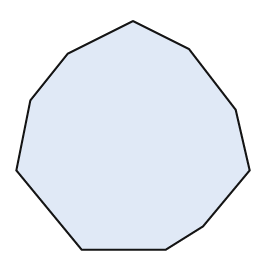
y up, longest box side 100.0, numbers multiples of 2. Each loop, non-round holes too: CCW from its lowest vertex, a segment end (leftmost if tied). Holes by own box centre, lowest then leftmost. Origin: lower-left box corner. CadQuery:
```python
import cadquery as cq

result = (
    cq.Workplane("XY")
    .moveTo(28.0, 0.0)
    .lineTo(64.0, 0.0)
    .lineTo(80.0, 10.0)
    .lineTo(100.0, 34.0)
    .lineTo(94.0, 60.0)
    .lineTo(74.0, 86.0)
    .lineTo(50.0, 98.0)
    .lineTo(22.0, 84.0)
    .lineTo(6.0, 64.0)
    .lineTo(0.0, 34.0)
    .close()
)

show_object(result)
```